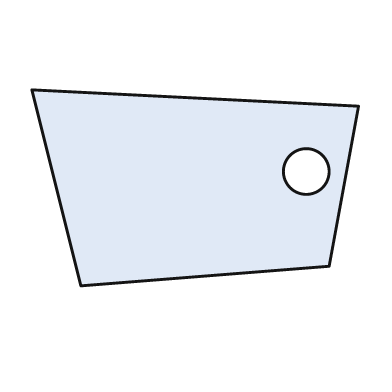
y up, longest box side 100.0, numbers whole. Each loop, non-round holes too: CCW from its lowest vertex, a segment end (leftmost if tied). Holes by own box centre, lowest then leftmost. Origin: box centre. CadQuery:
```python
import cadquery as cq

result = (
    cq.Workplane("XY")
    .moveTo(-35.0, -30.0)
    .lineTo(41.0, -24.0)
    .lineTo(50.0, 25.0)
    .lineTo(-50.0, 30.0)
    .close()
    .moveTo(34.0, 5.0)
    .circle(7.0)
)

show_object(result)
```